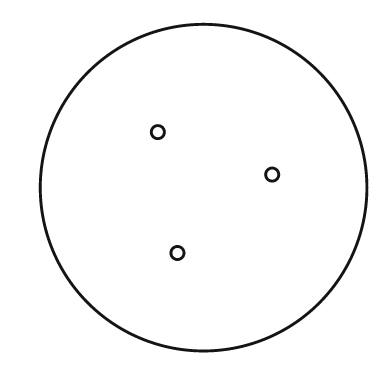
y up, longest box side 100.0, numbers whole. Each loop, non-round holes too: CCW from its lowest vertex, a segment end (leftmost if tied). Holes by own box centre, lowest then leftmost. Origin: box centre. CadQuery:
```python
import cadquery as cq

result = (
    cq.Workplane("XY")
    .moveTo(0.0, 0.0)
    .circle(50.0)
    .moveTo(-8.0, -20.0)
    .circle(2.0)
    .moveTo(21.0, 4.0)
    .circle(2.0)
    .moveTo(-14.0, 17.0)
    .circle(2.0)
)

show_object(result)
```